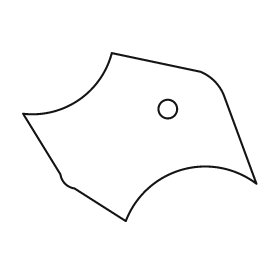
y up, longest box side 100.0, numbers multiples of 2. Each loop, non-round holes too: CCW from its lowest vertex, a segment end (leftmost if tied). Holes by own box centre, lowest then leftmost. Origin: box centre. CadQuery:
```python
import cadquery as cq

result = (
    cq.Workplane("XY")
    .moveTo(-6.0, -36.0)
    .threePointArc((18.0, -14.0), (50.0, -20.0))
    .lineTo(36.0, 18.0)
    .threePointArc((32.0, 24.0), (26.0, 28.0))
    .lineTo(-12.0, 36.0)
    .threePointArc((-26.0, 16.0), (-50.0, 10.0))
    .lineTo(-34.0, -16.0)
    .threePointArc((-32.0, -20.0), (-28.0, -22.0))
    .close()
    .moveTo(12.0, 12.0)
    .circle(4.0)
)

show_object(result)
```